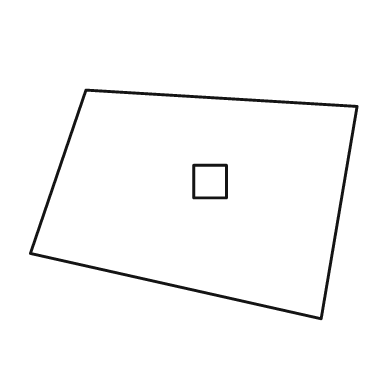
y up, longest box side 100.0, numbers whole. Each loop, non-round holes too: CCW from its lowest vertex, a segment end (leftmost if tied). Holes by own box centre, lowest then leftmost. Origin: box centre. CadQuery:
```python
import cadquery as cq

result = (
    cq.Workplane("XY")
    .moveTo(39.0, -35.0)
    .lineTo(50.0, 30.0)
    .lineTo(-33.0, 35.0)
    .lineTo(-50.0, -15.0)
    .close()
    .moveTo(0.0, 2.0)
    .lineTo(10.0, 2.0)
    .lineTo(10.0, 12.0)
    .lineTo(0.0, 12.0)
    .close()
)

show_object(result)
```